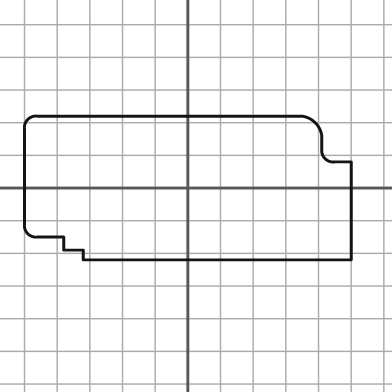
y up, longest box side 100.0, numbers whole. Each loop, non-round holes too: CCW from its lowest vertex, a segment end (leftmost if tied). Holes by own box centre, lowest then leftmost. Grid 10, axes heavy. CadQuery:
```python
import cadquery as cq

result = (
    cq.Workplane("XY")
    .moveTo(-32.0, -22.0)
    .lineTo(50.0, -22.0)
    .lineTo(50.0, 8.0)
    .lineTo(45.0, 8.0)
    .threePointArc((42.0, 9.0), (41.0, 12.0))
    .lineTo(41.0, 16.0)
    .threePointArc((39.0, 20.0), (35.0, 22.0))
    .lineTo(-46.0, 22.0)
    .threePointArc((-49.0, 21.0), (-50.0, 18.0))
    .lineTo(-50.0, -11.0)
    .threePointArc((-49.0, -14.0), (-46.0, -15.0))
    .lineTo(-38.0, -15.0)
    .lineTo(-38.0, -19.0)
    .lineTo(-32.0, -19.0)
    .close()
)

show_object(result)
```